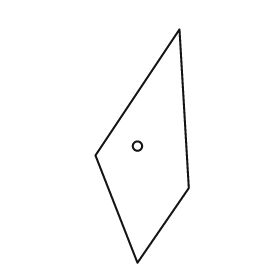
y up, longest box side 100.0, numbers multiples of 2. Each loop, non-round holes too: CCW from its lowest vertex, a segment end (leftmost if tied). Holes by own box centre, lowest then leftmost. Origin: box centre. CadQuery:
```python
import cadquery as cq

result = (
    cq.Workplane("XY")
    .moveTo(-2.0, -50.0)
    .lineTo(20.0, -18.0)
    .lineTo(16.0, 50.0)
    .lineTo(-20.0, -4.0)
    .close()
    .moveTo(-2.0, 0.0)
    .circle(2.0)
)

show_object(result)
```